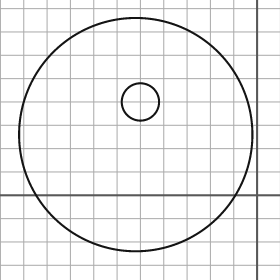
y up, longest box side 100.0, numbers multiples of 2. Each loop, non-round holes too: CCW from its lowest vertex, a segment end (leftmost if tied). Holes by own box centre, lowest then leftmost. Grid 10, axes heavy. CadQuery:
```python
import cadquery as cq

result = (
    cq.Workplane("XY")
    .moveTo(-52.0, 26.0)
    .circle(50.0)
    .moveTo(-50.0, 40.0)
    .circle(8.0)
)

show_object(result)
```